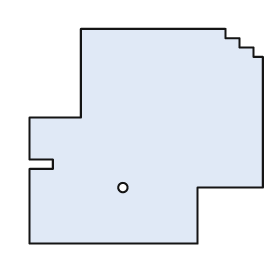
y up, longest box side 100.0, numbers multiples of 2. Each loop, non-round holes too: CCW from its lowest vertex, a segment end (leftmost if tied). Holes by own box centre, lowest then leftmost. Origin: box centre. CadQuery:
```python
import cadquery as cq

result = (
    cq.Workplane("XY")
    .moveTo(-50.0, -46.0)
    .lineTo(22.0, -46.0)
    .lineTo(22.0, -22.0)
    .lineTo(50.0, -22.0)
    .lineTo(50.0, 34.0)
    .lineTo(46.0, 34.0)
    .lineTo(46.0, 38.0)
    .lineTo(40.0, 38.0)
    .lineTo(40.0, 42.0)
    .lineTo(34.0, 42.0)
    .lineTo(34.0, 46.0)
    .lineTo(-28.0, 46.0)
    .lineTo(-28.0, 8.0)
    .lineTo(-50.0, 8.0)
    .lineTo(-50.0, -10.0)
    .lineTo(-40.0, -10.0)
    .lineTo(-40.0, -14.0)
    .lineTo(-50.0, -14.0)
    .close()
    .moveTo(-10.0, -22.0)
    .circle(2.0)
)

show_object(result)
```